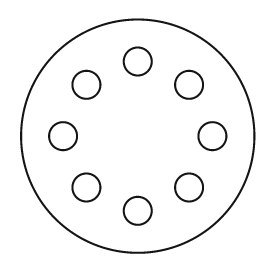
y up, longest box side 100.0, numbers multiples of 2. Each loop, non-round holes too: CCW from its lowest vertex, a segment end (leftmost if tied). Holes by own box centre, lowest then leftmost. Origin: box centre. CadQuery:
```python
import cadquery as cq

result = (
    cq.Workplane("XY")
    .moveTo(0.0, 0.0)
    .circle(50.0)
    .moveTo(0.0, -32.0)
    .circle(6.0)
    .moveTo(-22.0, -22.0)
    .circle(6.0)
    .moveTo(22.0, -22.0)
    .circle(6.0)
    .moveTo(-32.0, 0.0)
    .circle(6.0)
    .moveTo(32.0, 0.0)
    .circle(6.0)
    .moveTo(-22.0, 22.0)
    .circle(6.0)
    .moveTo(22.0, 22.0)
    .circle(6.0)
    .moveTo(0.0, 32.0)
    .circle(6.0)
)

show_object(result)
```